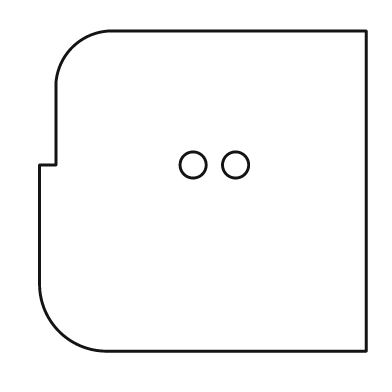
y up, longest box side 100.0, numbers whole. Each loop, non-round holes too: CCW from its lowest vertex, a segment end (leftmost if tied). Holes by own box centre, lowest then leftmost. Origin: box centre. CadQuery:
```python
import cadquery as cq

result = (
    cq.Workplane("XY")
    .moveTo(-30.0, -49.0)
    .lineTo(50.0, -49.0)
    .lineTo(50.0, 49.0)
    .lineTo(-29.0, 49.0)
    .threePointArc((-40.0, 44.0), (-45.0, 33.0))
    .lineTo(-45.0, 8.0)
    .lineTo(-50.0, 8.0)
    .lineTo(-50.0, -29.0)
    .threePointArc((-44.0, -43.0), (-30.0, -49.0))
    .close()
    .moveTo(-3.0, 8.0)
    .circle(4.0)
    .moveTo(10.0, 8.0)
    .circle(4.0)
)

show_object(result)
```